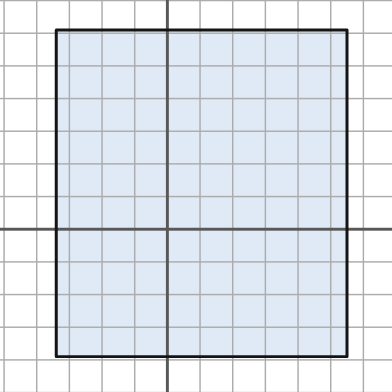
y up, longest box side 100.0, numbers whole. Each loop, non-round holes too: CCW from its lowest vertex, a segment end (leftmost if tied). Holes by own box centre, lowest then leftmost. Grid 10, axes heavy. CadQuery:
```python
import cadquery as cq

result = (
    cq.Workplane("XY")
    .moveTo(-34.0, -39.0)
    .lineTo(55.0, -39.0)
    .lineTo(55.0, 61.0)
    .lineTo(-34.0, 61.0)
    .close()
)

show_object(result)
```